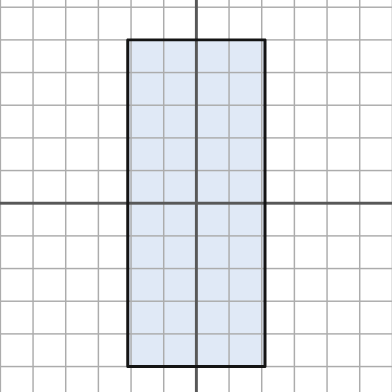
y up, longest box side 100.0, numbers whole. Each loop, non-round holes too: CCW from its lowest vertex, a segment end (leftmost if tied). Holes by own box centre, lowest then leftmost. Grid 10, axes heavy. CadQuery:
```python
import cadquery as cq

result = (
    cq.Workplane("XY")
    .moveTo(-21.0, -50.0)
    .lineTo(21.0, -50.0)
    .lineTo(21.0, 50.0)
    .lineTo(-21.0, 50.0)
    .close()
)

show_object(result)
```